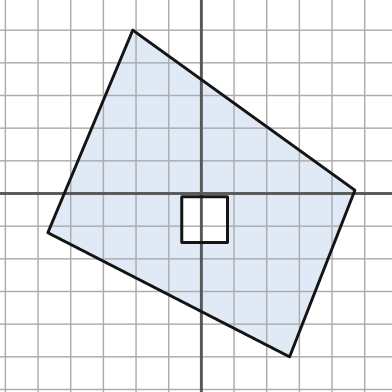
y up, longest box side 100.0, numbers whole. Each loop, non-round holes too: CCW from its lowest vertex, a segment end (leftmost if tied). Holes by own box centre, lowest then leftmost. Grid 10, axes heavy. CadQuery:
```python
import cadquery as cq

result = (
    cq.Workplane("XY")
    .moveTo(27.0, -50.0)
    .lineTo(47.0, 1.0)
    .lineTo(-21.0, 50.0)
    .lineTo(-47.0, -12.0)
    .close()
    .moveTo(-6.0, -15.0)
    .lineTo(8.0, -15.0)
    .lineTo(8.0, -1.0)
    .lineTo(-6.0, -1.0)
    .close()
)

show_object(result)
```